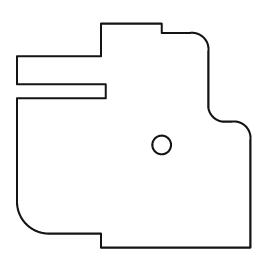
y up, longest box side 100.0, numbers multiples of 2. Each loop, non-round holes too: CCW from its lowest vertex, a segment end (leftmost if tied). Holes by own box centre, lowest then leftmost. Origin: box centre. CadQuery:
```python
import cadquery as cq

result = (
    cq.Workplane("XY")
    .moveTo(-14.0, -48.0)
    .lineTo(50.0, -48.0)
    .lineTo(50.0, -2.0)
    .threePointArc((48.0, 4.0), (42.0, 6.0))
    .lineTo(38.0, 6.0)
    .threePointArc((34.0, 8.0), (32.0, 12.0))
    .lineTo(32.0, 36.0)
    .threePointArc((30.0, 42.0), (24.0, 44.0))
    .lineTo(12.0, 44.0)
    .lineTo(12.0, 48.0)
    .lineTo(-14.0, 48.0)
    .lineTo(-14.0, 34.0)
    .lineTo(-50.0, 34.0)
    .lineTo(-50.0, 22.0)
    .lineTo(-12.0, 22.0)
    .lineTo(-12.0, 16.0)
    .lineTo(-50.0, 16.0)
    .lineTo(-50.0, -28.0)
    .threePointArc((-46.0, -38.0), (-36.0, -42.0))
    .lineTo(-14.0, -42.0)
    .close()
    .moveTo(12.0, -4.0)
    .circle(4.0)
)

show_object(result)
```